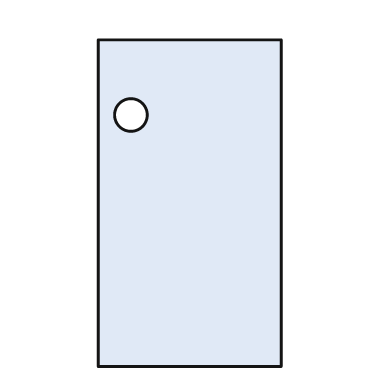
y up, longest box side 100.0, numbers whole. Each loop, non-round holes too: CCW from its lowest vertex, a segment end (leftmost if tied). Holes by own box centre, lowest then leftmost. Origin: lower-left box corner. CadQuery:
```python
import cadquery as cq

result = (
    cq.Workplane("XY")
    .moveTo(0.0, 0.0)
    .lineTo(56.0, 0.0)
    .lineTo(56.0, 100.0)
    .lineTo(0.0, 100.0)
    .close()
    .moveTo(10.0, 77.0)
    .circle(5.0)
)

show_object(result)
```